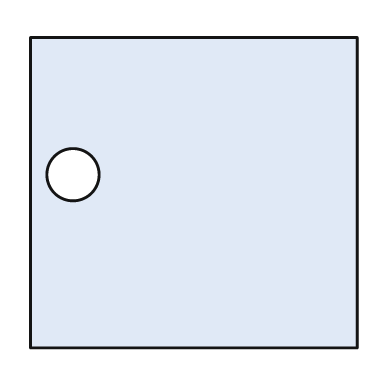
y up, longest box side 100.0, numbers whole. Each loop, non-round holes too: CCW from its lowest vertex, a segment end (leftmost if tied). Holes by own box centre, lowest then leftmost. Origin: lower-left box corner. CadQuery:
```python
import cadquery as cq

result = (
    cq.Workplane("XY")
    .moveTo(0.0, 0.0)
    .lineTo(100.0, 0.0)
    .lineTo(100.0, 95.0)
    .lineTo(0.0, 95.0)
    .close()
    .moveTo(13.0, 53.0)
    .circle(8.0)
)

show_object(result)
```